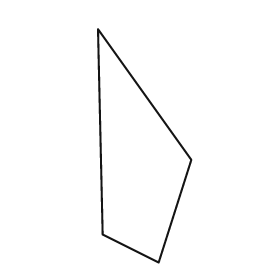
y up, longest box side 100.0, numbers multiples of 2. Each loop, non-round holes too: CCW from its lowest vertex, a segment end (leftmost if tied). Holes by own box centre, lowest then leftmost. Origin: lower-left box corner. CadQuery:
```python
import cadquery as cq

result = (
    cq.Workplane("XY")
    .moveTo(26.0, 0.0)
    .lineTo(40.0, 44.0)
    .lineTo(0.0, 100.0)
    .lineTo(2.0, 12.0)
    .close()
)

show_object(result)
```